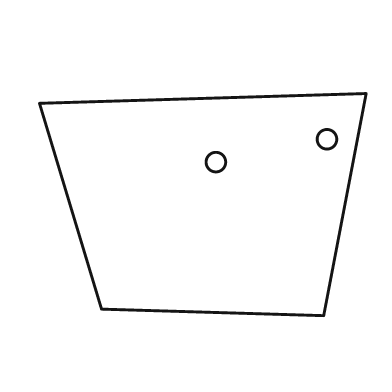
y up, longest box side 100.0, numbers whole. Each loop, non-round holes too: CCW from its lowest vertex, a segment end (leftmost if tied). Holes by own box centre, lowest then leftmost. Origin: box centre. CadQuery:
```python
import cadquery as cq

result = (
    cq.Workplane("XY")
    .moveTo(37.0, -34.0)
    .lineTo(50.0, 34.0)
    .lineTo(-50.0, 31.0)
    .lineTo(-31.0, -32.0)
    .close()
    .moveTo(4.0, 13.0)
    .circle(3.0)
    .moveTo(38.0, 20.0)
    .circle(3.0)
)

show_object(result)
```